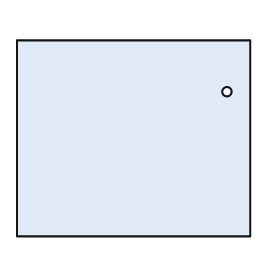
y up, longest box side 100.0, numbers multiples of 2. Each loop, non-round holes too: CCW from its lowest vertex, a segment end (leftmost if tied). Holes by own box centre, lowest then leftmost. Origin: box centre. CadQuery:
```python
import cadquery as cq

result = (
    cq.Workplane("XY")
    .moveTo(-50.0, -42.0)
    .lineTo(50.0, -42.0)
    .lineTo(50.0, 42.0)
    .lineTo(-50.0, 42.0)
    .close()
    .moveTo(40.0, 20.0)
    .circle(2.0)
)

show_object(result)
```